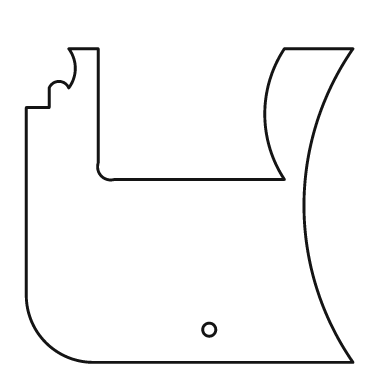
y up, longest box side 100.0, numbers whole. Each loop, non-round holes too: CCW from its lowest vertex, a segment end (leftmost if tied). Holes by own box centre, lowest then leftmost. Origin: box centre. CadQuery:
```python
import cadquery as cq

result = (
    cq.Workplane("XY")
    .moveTo(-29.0, -48.0)
    .lineTo(50.0, -48.0)
    .threePointArc((35.0, 0.0), (50.0, 48.0))
    .lineTo(29.0, 48.0)
    .threePointArc((23.0, 28.0), (29.0, 8.0))
    .lineTo(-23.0, 8.0)
    .threePointArc((-27.0, 9.0), (-28.0, 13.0))
    .lineTo(-28.0, 48.0)
    .lineTo(-37.0, 48.0)
    .threePointArc((-35.0, 42.0), (-37.0, 36.0))
    .threePointArc((-40.0, 38.0), (-43.0, 36.0))
    .lineTo(-43.0, 30.0)
    .lineTo(-50.0, 30.0)
    .lineTo(-50.0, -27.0)
    .threePointArc((-44.0, -42.0), (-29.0, -48.0))
    .close()
    .moveTo(6.0, -38.0)
    .circle(2.0)
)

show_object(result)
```